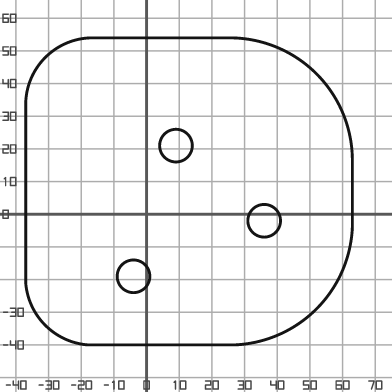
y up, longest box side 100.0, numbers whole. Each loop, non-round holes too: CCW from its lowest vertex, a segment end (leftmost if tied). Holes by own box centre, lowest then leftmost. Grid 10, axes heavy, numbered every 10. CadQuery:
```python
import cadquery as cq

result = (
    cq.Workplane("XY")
    .moveTo(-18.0, -40.0)
    .lineTo(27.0, -40.0)
    .threePointArc((52.0, -29.0), (63.0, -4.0))
    .lineTo(63.0, 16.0)
    .threePointArc((52.0, 43.0), (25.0, 54.0))
    .lineTo(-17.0, 54.0)
    .threePointArc((-31.0, 48.0), (-37.0, 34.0))
    .lineTo(-37.0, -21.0)
    .threePointArc((-31.0, -34.0), (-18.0, -40.0))
    .close()
    .moveTo(-4.0, -19.0)
    .circle(5.0)
    .moveTo(36.0, -2.0)
    .circle(5.0)
    .moveTo(9.0, 21.0)
    .circle(5.0)
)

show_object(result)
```